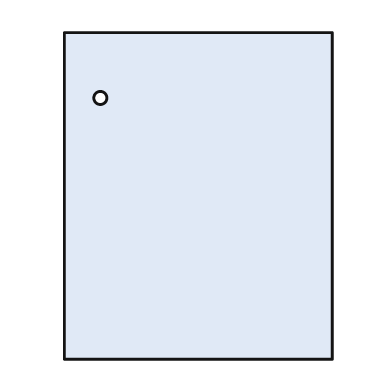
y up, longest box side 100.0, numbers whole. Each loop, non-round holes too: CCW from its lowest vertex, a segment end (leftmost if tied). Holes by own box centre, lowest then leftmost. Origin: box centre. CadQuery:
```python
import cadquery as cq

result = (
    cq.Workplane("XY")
    .moveTo(-41.0, -50.0)
    .lineTo(41.0, -50.0)
    .lineTo(41.0, 50.0)
    .lineTo(-41.0, 50.0)
    .close()
    .moveTo(-30.0, 30.0)
    .circle(2.0)
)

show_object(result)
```